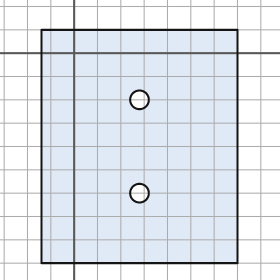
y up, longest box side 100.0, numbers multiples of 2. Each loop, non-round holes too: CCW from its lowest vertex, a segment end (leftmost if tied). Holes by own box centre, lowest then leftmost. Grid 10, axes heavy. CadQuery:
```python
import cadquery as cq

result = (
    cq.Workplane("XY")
    .moveTo(-14.0, -90.0)
    .lineTo(70.0, -90.0)
    .lineTo(70.0, 10.0)
    .lineTo(-14.0, 10.0)
    .close()
    .moveTo(28.0, -60.0)
    .circle(4.0)
    .moveTo(28.0, -20.0)
    .circle(4.0)
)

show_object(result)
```